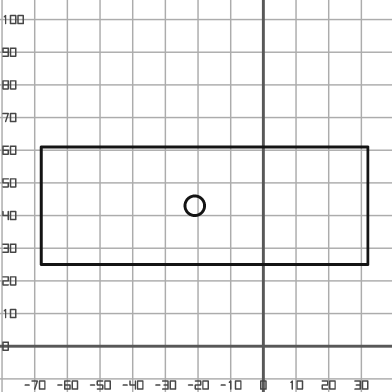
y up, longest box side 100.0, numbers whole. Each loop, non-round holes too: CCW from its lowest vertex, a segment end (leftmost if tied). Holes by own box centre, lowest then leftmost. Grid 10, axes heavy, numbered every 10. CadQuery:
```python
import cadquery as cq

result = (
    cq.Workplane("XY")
    .moveTo(-68.0, 25.0)
    .lineTo(32.0, 25.0)
    .lineTo(32.0, 61.0)
    .lineTo(-68.0, 61.0)
    .close()
    .moveTo(-21.0, 43.0)
    .circle(3.0)
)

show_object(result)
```